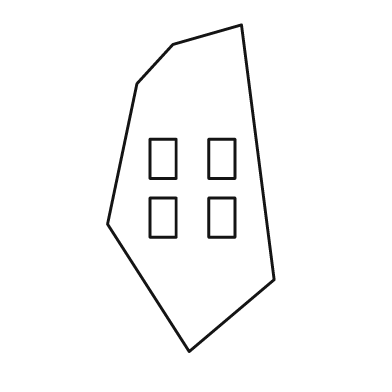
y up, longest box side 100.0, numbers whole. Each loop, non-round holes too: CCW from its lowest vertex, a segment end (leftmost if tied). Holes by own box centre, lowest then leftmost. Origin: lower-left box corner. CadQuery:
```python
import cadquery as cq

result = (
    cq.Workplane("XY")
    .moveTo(25.0, 0.0)
    .lineTo(51.0, 22.0)
    .lineTo(41.0, 100.0)
    .lineTo(20.0, 94.0)
    .lineTo(9.0, 82.0)
    .lineTo(0.0, 39.0)
    .close()
    .moveTo(13.0, 35.0)
    .lineTo(21.0, 35.0)
    .lineTo(21.0, 47.0)
    .lineTo(13.0, 47.0)
    .close()
    .moveTo(31.0, 35.0)
    .lineTo(39.0, 35.0)
    .lineTo(39.0, 47.0)
    .lineTo(31.0, 47.0)
    .close()
    .moveTo(13.0, 53.0)
    .lineTo(21.0, 53.0)
    .lineTo(21.0, 65.0)
    .lineTo(13.0, 65.0)
    .close()
    .moveTo(31.0, 53.0)
    .lineTo(39.0, 53.0)
    .lineTo(39.0, 65.0)
    .lineTo(31.0, 65.0)
    .close()
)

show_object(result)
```